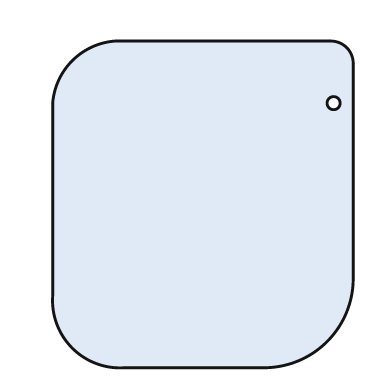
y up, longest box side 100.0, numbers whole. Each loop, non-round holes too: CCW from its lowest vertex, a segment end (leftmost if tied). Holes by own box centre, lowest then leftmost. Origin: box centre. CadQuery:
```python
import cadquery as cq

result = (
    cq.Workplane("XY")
    .moveTo(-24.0, -50.0)
    .lineTo(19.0, -50.0)
    .threePointArc((38.0, -42.0), (46.0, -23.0))
    .lineTo(46.0, 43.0)
    .threePointArc((44.0, 48.0), (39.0, 50.0))
    .lineTo(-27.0, 50.0)
    .threePointArc((-40.0, 44.0), (-46.0, 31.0))
    .lineTo(-46.0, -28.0)
    .threePointArc((-40.0, -44.0), (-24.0, -50.0))
    .close()
    .moveTo(40.0, 31.0)
    .circle(2.0)
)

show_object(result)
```